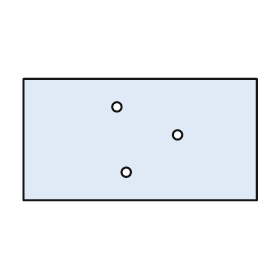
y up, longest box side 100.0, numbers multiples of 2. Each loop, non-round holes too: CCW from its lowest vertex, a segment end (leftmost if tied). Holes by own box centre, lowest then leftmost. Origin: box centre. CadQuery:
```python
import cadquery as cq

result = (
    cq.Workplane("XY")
    .moveTo(-50.0, -26.0)
    .lineTo(50.0, -26.0)
    .lineTo(50.0, 26.0)
    .lineTo(-50.0, 26.0)
    .close()
    .moveTo(-6.0, -14.0)
    .circle(2.0)
    .moveTo(16.0, 2.0)
    .circle(2.0)
    .moveTo(-10.0, 14.0)
    .circle(2.0)
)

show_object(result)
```